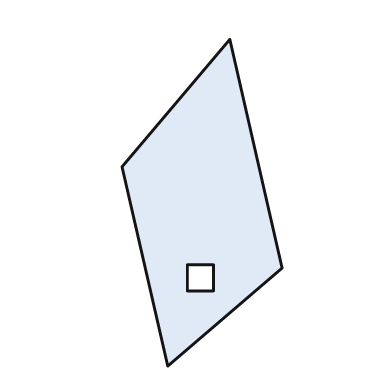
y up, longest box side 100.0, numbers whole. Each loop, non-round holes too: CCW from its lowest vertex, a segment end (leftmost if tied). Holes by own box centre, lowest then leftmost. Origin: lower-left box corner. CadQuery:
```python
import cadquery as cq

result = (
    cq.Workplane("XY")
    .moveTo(14.0, 0.0)
    .lineTo(49.0, 30.0)
    .lineTo(33.0, 100.0)
    .lineTo(0.0, 61.0)
    .close()
    .moveTo(20.0, 23.0)
    .lineTo(28.0, 23.0)
    .lineTo(28.0, 31.0)
    .lineTo(20.0, 31.0)
    .close()
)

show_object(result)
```